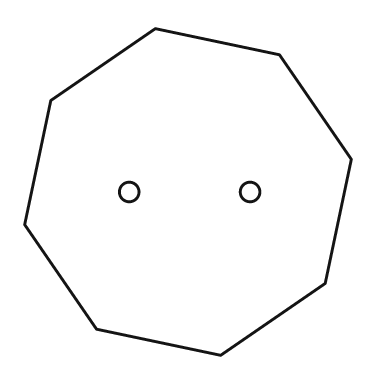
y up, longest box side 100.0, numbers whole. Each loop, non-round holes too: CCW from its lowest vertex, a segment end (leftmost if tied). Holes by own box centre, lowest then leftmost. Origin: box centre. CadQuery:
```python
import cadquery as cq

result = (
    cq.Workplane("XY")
    .moveTo(10.0, -50.0)
    .lineTo(42.0, -28.0)
    .lineTo(50.0, 10.0)
    .lineTo(28.0, 42.0)
    .lineTo(-10.0, 50.0)
    .lineTo(-42.0, 28.0)
    .lineTo(-50.0, -10.0)
    .lineTo(-28.0, -42.0)
    .close()
    .moveTo(-18.0, 0.0)
    .circle(3.0)
    .moveTo(19.0, 0.0)
    .circle(3.0)
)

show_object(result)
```